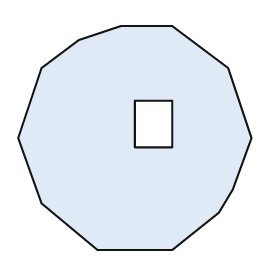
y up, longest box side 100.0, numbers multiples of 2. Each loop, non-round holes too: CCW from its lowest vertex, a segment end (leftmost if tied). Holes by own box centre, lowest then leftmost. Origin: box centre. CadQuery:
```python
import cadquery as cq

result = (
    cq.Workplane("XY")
    .moveTo(-16.0, -48.0)
    .lineTo(16.0, -48.0)
    .lineTo(36.0, -32.0)
    .lineTo(42.0, -22.0)
    .lineTo(50.0, 0.0)
    .lineTo(40.0, 30.0)
    .lineTo(16.0, 48.0)
    .lineTo(-6.0, 48.0)
    .lineTo(-24.0, 42.0)
    .lineTo(-40.0, 30.0)
    .lineTo(-50.0, 0.0)
    .lineTo(-40.0, -28.0)
    .close()
    .moveTo(0.0, -4.0)
    .lineTo(16.0, -4.0)
    .lineTo(16.0, 16.0)
    .lineTo(0.0, 16.0)
    .close()
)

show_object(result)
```